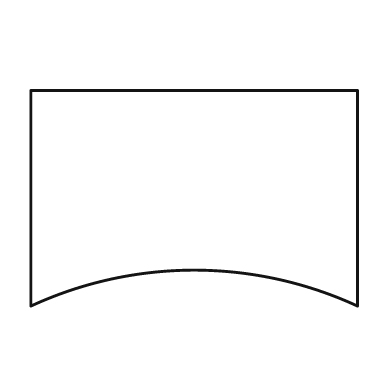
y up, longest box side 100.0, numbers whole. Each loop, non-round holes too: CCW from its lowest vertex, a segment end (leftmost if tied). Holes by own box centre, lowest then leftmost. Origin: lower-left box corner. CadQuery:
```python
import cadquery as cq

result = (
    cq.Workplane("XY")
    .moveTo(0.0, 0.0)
    .threePointArc((50.0, 11.0), (100.0, 0.0))
    .lineTo(100.0, 66.0)
    .lineTo(0.0, 66.0)
    .close()
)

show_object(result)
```